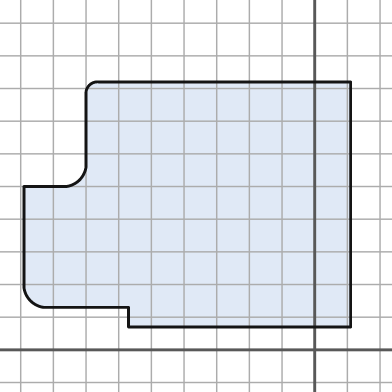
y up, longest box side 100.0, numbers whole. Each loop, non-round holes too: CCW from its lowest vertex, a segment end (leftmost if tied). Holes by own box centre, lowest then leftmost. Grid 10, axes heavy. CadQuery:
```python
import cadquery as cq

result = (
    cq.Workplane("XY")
    .moveTo(-57.0, 7.0)
    .lineTo(11.0, 7.0)
    .lineTo(11.0, 82.0)
    .lineTo(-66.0, 82.0)
    .threePointArc((-69.0, 81.0), (-70.0, 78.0))
    .lineTo(-70.0, 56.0)
    .threePointArc((-72.0, 52.0), (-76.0, 50.0))
    .lineTo(-89.0, 50.0)
    .lineTo(-89.0, 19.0)
    .threePointArc((-87.0, 15.0), (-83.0, 13.0))
    .lineTo(-57.0, 13.0)
    .close()
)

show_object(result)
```